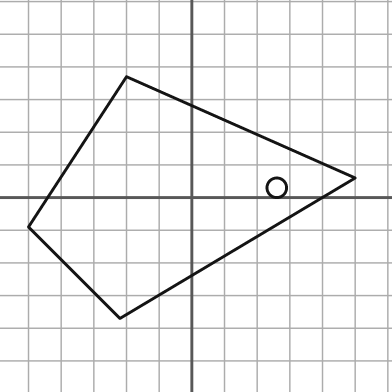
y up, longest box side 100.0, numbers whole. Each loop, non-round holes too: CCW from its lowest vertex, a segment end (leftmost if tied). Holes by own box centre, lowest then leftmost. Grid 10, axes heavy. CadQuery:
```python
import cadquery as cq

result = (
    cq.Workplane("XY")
    .moveTo(-22.0, -37.0)
    .lineTo(50.0, 6.0)
    .lineTo(-20.0, 37.0)
    .lineTo(-50.0, -9.0)
    .close()
    .moveTo(26.0, 3.0)
    .circle(3.0)
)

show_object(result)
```